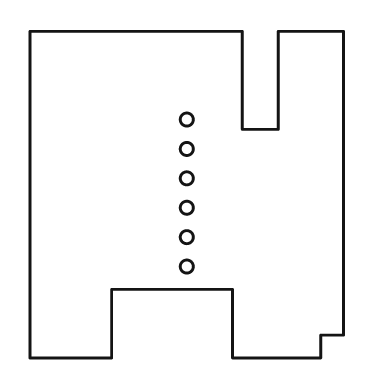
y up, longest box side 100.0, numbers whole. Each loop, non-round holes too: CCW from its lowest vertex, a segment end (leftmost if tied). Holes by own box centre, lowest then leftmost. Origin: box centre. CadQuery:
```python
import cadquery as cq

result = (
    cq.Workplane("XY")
    .moveTo(-48.0, -50.0)
    .lineTo(-23.0, -50.0)
    .lineTo(-23.0, -29.0)
    .lineTo(14.0, -29.0)
    .lineTo(14.0, -50.0)
    .lineTo(41.0, -50.0)
    .lineTo(41.0, -43.0)
    .lineTo(48.0, -43.0)
    .lineTo(48.0, 50.0)
    .lineTo(28.0, 50.0)
    .lineTo(28.0, 20.0)
    .lineTo(17.0, 20.0)
    .lineTo(17.0, 50.0)
    .lineTo(-48.0, 50.0)
    .close()
    .moveTo(0.0, -22.0)
    .circle(2.0)
    .moveTo(0.0, -13.0)
    .circle(2.0)
    .moveTo(0.0, -4.0)
    .circle(2.0)
    .moveTo(0.0, 5.0)
    .circle(2.0)
    .moveTo(0.0, 14.0)
    .circle(2.0)
    .moveTo(0.0, 23.0)
    .circle(2.0)
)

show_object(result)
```